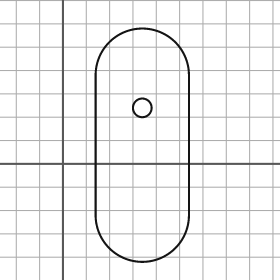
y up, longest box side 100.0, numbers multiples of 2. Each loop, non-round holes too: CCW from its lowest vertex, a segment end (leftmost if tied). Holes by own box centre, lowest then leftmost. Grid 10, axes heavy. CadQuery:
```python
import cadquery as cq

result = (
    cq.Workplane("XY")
    .moveTo(14.0, -22.0)
    .threePointArc((34.0, -42.0), (54.0, -22.0))
    .lineTo(54.0, 38.0)
    .threePointArc((34.0, 58.0), (14.0, 38.0))
    .close()
    .moveTo(34.0, 24.0)
    .circle(4.0)
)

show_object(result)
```